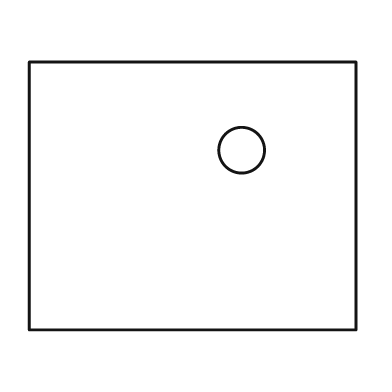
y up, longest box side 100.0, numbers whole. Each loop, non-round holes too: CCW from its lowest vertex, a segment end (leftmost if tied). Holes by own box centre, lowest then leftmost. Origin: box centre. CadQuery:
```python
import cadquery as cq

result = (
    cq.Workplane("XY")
    .moveTo(-50.0, -41.0)
    .lineTo(50.0, -41.0)
    .lineTo(50.0, 41.0)
    .lineTo(-50.0, 41.0)
    .close()
    .moveTo(15.0, 14.0)
    .circle(7.0)
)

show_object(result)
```